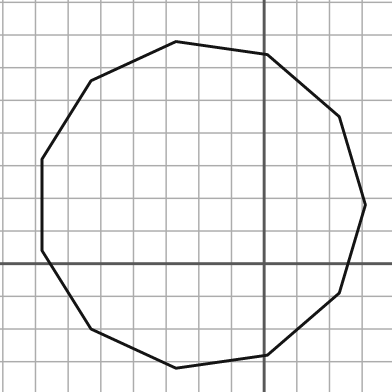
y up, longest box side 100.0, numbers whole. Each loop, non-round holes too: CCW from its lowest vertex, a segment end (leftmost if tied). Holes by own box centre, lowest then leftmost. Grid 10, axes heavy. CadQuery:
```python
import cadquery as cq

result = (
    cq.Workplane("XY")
    .moveTo(-27.0, -32.0)
    .lineTo(1.0, -28.0)
    .lineTo(23.0, -9.0)
    .lineTo(31.0, 18.0)
    .lineTo(23.0, 45.0)
    .lineTo(1.0, 64.0)
    .lineTo(-27.0, 68.0)
    .lineTo(-53.0, 56.0)
    .lineTo(-68.0, 32.0)
    .lineTo(-68.0, 4.0)
    .lineTo(-53.0, -20.0)
    .close()
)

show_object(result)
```